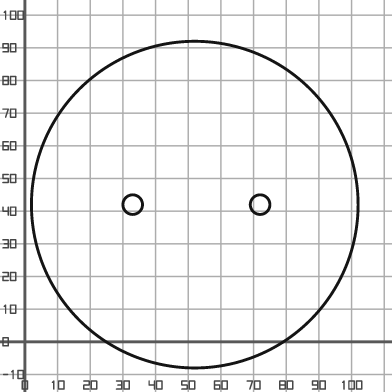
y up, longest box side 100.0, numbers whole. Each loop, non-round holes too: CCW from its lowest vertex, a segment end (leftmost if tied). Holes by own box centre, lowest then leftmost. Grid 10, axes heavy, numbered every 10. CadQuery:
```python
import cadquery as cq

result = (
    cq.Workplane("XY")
    .moveTo(52.0, 42.0)
    .circle(50.0)
    .moveTo(33.0, 42.0)
    .circle(3.0)
    .moveTo(72.0, 42.0)
    .circle(3.0)
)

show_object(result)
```